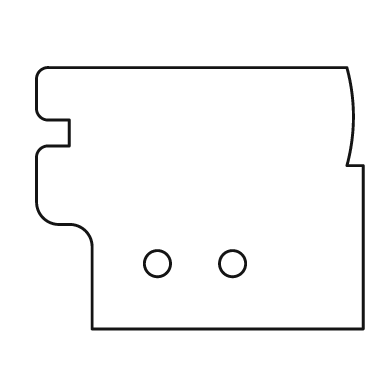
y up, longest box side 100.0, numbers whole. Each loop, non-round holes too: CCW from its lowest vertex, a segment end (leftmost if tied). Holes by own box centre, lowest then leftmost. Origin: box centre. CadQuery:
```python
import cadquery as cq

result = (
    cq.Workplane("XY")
    .moveTo(-33.0, -40.0)
    .lineTo(50.0, -40.0)
    .lineTo(50.0, 10.0)
    .lineTo(45.0, 10.0)
    .threePointArc((47.0, 25.0), (45.0, 40.0))
    .lineTo(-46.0, 40.0)
    .threePointArc((-49.0, 39.0), (-50.0, 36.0))
    .lineTo(-50.0, 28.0)
    .threePointArc((-49.0, 25.0), (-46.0, 24.0))
    .lineTo(-40.0, 24.0)
    .lineTo(-40.0, 16.0)
    .lineTo(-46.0, 16.0)
    .threePointArc((-49.0, 15.0), (-50.0, 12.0))
    .lineTo(-50.0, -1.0)
    .threePointArc((-48.0, -6.0), (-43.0, -8.0))
    .lineTo(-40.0, -8.0)
    .threePointArc((-35.0, -10.0), (-33.0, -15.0))
    .close()
    .moveTo(-13.0, -20.0)
    .circle(4.0)
    .moveTo(10.0, -20.0)
    .circle(4.0)
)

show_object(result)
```